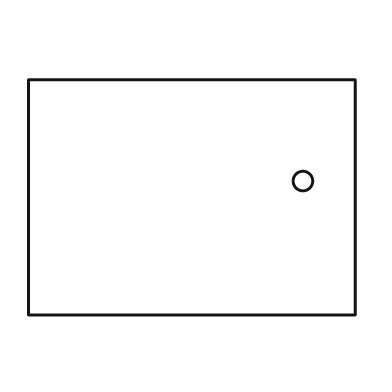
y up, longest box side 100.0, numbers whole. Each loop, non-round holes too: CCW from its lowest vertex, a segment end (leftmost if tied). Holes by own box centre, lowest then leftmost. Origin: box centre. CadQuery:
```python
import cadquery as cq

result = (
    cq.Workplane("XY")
    .moveTo(-50.0, -36.0)
    .lineTo(50.0, -36.0)
    .lineTo(50.0, 36.0)
    .lineTo(-50.0, 36.0)
    .close()
    .moveTo(34.0, 5.0)
    .circle(3.0)
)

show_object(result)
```